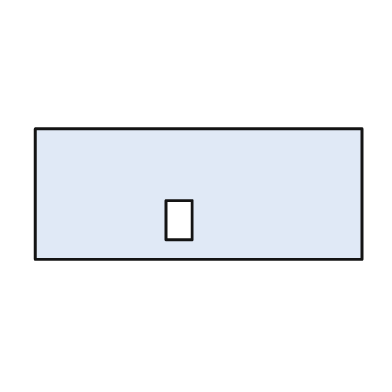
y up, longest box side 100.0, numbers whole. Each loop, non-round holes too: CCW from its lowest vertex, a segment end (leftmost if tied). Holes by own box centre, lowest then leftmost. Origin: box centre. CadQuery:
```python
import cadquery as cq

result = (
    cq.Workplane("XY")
    .moveTo(-50.0, -20.0)
    .lineTo(50.0, -20.0)
    .lineTo(50.0, 20.0)
    .lineTo(-50.0, 20.0)
    .close()
    .moveTo(-10.0, -14.0)
    .lineTo(-2.0, -14.0)
    .lineTo(-2.0, -2.0)
    .lineTo(-10.0, -2.0)
    .close()
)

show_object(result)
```